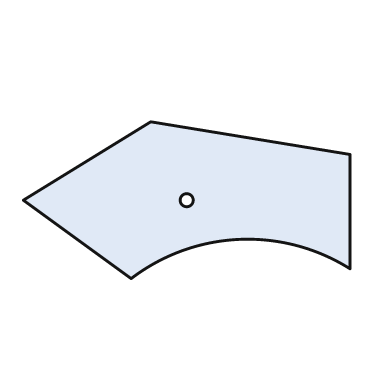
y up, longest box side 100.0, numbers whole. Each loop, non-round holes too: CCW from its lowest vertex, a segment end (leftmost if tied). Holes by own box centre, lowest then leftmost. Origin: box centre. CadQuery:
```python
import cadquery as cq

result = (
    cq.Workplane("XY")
    .moveTo(-17.0, -24.0)
    .threePointArc((16.0, -12.0), (50.0, -21.0))
    .lineTo(50.0, 14.0)
    .lineTo(-11.0, 24.0)
    .lineTo(-50.0, 0.0)
    .close()
    .moveTo(0.0, 0.0)
    .circle(2.0)
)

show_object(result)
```